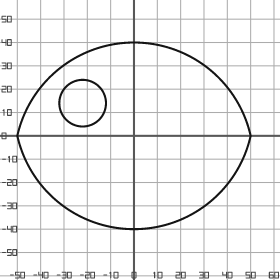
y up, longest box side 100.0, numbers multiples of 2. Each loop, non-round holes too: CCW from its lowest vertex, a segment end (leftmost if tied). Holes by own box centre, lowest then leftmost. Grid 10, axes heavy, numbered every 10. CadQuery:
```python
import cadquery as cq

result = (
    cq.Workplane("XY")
    .moveTo(-50.0, 0.0)
    .threePointArc((0.0, -40.0), (50.0, 0.0))
    .threePointArc((0.0, 40.0), (-50.0, 0.0))
    .close()
    .moveTo(-22.0, 14.0)
    .circle(10.0)
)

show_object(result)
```